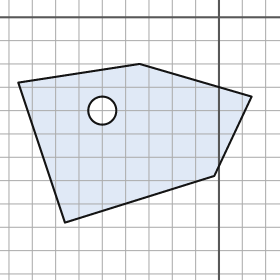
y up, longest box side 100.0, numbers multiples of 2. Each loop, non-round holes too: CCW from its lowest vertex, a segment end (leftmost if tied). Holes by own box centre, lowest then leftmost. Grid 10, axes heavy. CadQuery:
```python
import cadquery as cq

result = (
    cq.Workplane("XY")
    .moveTo(-66.0, -88.0)
    .lineTo(-2.0, -68.0)
    .lineTo(14.0, -34.0)
    .lineTo(-34.0, -20.0)
    .lineTo(-86.0, -28.0)
    .close()
    .moveTo(-50.0, -40.0)
    .circle(6.0)
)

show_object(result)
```